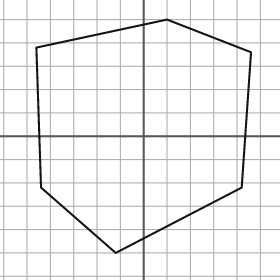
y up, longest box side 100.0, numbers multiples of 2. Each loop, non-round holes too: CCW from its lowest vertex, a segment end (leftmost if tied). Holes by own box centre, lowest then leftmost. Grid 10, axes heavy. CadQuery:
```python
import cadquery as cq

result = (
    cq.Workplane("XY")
    .moveTo(-12.0, -50.0)
    .lineTo(42.0, -22.0)
    .lineTo(46.0, 36.0)
    .lineTo(10.0, 50.0)
    .lineTo(-46.0, 38.0)
    .lineTo(-44.0, -22.0)
    .close()
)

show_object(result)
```